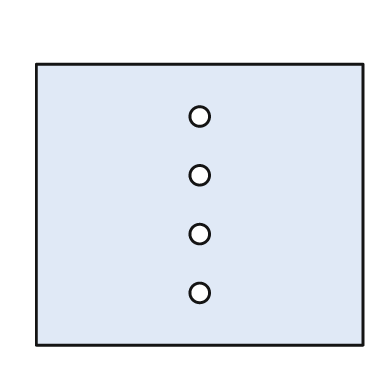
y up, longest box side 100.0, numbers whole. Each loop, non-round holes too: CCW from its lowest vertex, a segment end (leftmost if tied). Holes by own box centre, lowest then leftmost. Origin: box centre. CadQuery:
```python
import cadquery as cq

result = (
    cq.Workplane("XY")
    .moveTo(-50.0, -43.0)
    .lineTo(50.0, -43.0)
    .lineTo(50.0, 43.0)
    .lineTo(-50.0, 43.0)
    .close()
    .moveTo(0.0, -27.0)
    .circle(3.0)
    .moveTo(0.0, -9.0)
    .circle(3.0)
    .moveTo(0.0, 9.0)
    .circle(3.0)
    .moveTo(0.0, 27.0)
    .circle(3.0)
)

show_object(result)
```